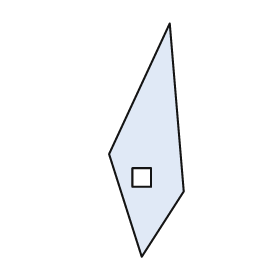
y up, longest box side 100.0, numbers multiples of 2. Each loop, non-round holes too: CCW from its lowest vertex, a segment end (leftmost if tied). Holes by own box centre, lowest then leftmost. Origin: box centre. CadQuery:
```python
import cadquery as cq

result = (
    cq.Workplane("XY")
    .moveTo(-2.0, -50.0)
    .lineTo(16.0, -22.0)
    .lineTo(10.0, 50.0)
    .lineTo(-16.0, -6.0)
    .close()
    .moveTo(-6.0, -20.0)
    .lineTo(2.0, -20.0)
    .lineTo(2.0, -12.0)
    .lineTo(-6.0, -12.0)
    .close()
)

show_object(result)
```